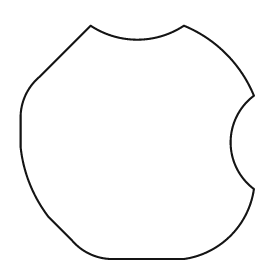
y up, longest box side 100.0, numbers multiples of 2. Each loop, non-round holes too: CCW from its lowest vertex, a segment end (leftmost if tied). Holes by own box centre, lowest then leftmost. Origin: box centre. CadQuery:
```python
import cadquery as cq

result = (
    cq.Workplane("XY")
    .moveTo(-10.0, -50.0)
    .lineTo(20.0, -50.0)
    .threePointArc((40.0, -40.0), (50.0, -20.0))
    .threePointArc((40.0, 0.0), (50.0, 20.0))
    .threePointArc((38.0, 38.0), (20.0, 50.0))
    .threePointArc((0.0, 44.0), (-20.0, 50.0))
    .lineTo(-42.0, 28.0)
    .threePointArc((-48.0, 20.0), (-50.0, 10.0))
    .lineTo(-50.0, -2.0)
    .threePointArc((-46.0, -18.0), (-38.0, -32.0))
    .lineTo(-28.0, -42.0)
    .threePointArc((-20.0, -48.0), (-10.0, -50.0))
    .close()
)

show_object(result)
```